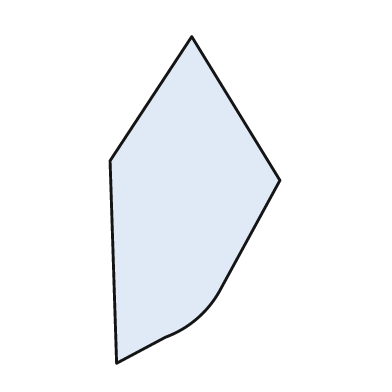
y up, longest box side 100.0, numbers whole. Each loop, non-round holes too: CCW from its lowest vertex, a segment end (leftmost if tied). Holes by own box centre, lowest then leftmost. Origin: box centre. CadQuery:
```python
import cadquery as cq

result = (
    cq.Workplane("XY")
    .moveTo(-24.0, -50.0)
    .lineTo(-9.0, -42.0)
    .threePointArc((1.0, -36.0), (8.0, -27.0))
    .lineTo(26.0, 6.0)
    .lineTo(-1.0, 50.0)
    .lineTo(-26.0, 12.0)
    .close()
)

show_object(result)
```